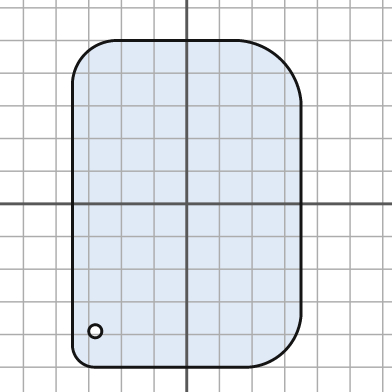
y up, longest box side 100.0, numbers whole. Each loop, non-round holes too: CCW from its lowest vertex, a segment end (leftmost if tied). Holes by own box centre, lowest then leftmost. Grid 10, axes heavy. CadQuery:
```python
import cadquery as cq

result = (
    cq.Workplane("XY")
    .moveTo(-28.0, -50.0)
    .lineTo(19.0, -50.0)
    .threePointArc((30.0, -45.0), (35.0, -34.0))
    .lineTo(35.0, 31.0)
    .threePointArc((29.0, 44.0), (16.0, 50.0))
    .lineTo(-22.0, 50.0)
    .threePointArc((-31.0, 46.0), (-35.0, 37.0))
    .lineTo(-35.0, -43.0)
    .threePointArc((-33.0, -48.0), (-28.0, -50.0))
    .close()
    .moveTo(-28.0, -39.0)
    .circle(2.0)
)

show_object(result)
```